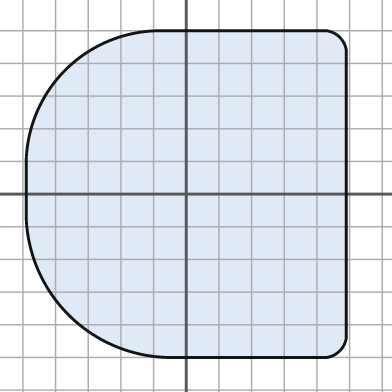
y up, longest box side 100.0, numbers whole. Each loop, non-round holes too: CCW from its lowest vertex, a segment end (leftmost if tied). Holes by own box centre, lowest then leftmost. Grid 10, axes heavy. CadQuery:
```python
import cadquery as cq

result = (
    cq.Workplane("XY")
    .moveTo(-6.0, -50.0)
    .lineTo(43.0, -50.0)
    .threePointArc((47.0, -48.0), (49.0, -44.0))
    .lineTo(49.0, 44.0)
    .threePointArc((47.0, 48.0), (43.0, 50.0))
    .lineTo(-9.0, 50.0)
    .threePointArc((-37.0, 38.0), (-49.0, 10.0))
    .lineTo(-49.0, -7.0)
    .threePointArc((-36.0, -37.0), (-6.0, -50.0))
    .close()
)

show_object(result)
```